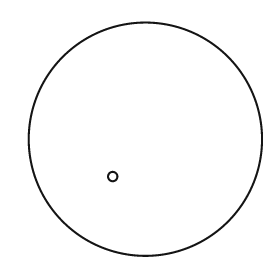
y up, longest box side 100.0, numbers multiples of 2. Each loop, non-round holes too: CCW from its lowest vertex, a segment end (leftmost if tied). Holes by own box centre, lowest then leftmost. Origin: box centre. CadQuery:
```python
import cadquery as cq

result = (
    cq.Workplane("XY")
    .moveTo(0.0, 0.0)
    .circle(50.0)
    .moveTo(-14.0, -16.0)
    .circle(2.0)
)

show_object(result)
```